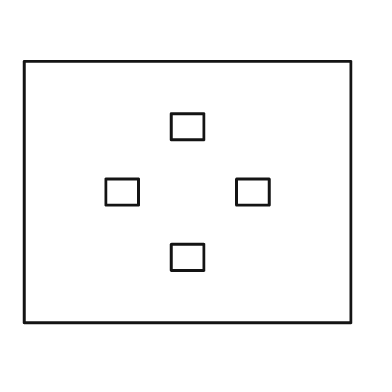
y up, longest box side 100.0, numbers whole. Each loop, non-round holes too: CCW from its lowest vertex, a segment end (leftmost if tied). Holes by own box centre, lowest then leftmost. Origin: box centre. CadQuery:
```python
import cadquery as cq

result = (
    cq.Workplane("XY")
    .moveTo(-50.0, -40.0)
    .lineTo(50.0, -40.0)
    .lineTo(50.0, 40.0)
    .lineTo(-50.0, 40.0)
    .close()
    .moveTo(-5.0, -24.0)
    .lineTo(5.0, -24.0)
    .lineTo(5.0, -16.0)
    .lineTo(-5.0, -16.0)
    .close()
    .moveTo(-25.0, -4.0)
    .lineTo(-15.0, -4.0)
    .lineTo(-15.0, 4.0)
    .lineTo(-25.0, 4.0)
    .close()
    .moveTo(15.0, -4.0)
    .lineTo(25.0, -4.0)
    .lineTo(25.0, 4.0)
    .lineTo(15.0, 4.0)
    .close()
    .moveTo(-5.0, 16.0)
    .lineTo(5.0, 16.0)
    .lineTo(5.0, 24.0)
    .lineTo(-5.0, 24.0)
    .close()
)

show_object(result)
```